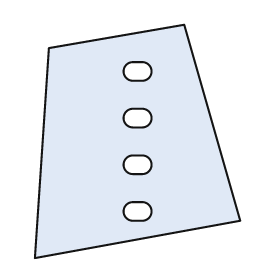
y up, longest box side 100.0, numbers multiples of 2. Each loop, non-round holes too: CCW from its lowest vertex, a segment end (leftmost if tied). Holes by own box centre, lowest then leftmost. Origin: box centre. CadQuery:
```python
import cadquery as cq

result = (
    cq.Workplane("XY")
    .moveTo(-44.0, -50.0)
    .lineTo(44.0, -34.0)
    .lineTo(20.0, 50.0)
    .lineTo(-38.0, 40.0)
    .close()
    .moveTo(-2.0, -34.0)
    .lineTo(2.0, -34.0)
    .threePointArc((6.0, -30.0), (2.0, -26.0))
    .lineTo(-2.0, -26.0)
    .threePointArc((-6.0, -30.0), (-2.0, -34.0))
    .close()
    .moveTo(-2.0, -14.0)
    .lineTo(2.0, -14.0)
    .threePointArc((6.0, -10.0), (2.0, -6.0))
    .lineTo(-2.0, -6.0)
    .threePointArc((-6.0, -10.0), (-2.0, -14.0))
    .close()
    .moveTo(-2.0, 6.0)
    .lineTo(2.0, 6.0)
    .threePointArc((6.0, 10.0), (2.0, 14.0))
    .lineTo(-2.0, 14.0)
    .threePointArc((-6.0, 10.0), (-2.0, 6.0))
    .close()
    .moveTo(-2.0, 26.0)
    .lineTo(2.0, 26.0)
    .threePointArc((6.0, 30.0), (2.0, 34.0))
    .lineTo(-2.0, 34.0)
    .threePointArc((-6.0, 30.0), (-2.0, 26.0))
    .close()
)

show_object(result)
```